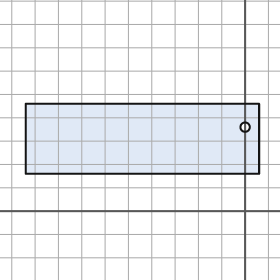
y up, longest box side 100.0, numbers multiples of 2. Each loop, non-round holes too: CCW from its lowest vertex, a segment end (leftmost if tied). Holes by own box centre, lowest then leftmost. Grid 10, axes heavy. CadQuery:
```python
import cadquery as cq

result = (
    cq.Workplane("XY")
    .moveTo(-94.0, 16.0)
    .lineTo(6.0, 16.0)
    .lineTo(6.0, 46.0)
    .lineTo(-94.0, 46.0)
    .close()
    .moveTo(0.0, 36.0)
    .circle(2.0)
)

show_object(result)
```